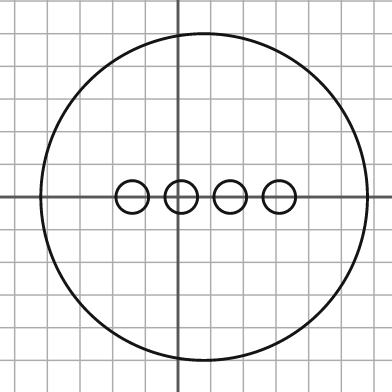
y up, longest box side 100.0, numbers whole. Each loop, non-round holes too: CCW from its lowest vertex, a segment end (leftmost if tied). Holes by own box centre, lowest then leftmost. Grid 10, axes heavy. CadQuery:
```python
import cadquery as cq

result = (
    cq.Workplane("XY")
    .moveTo(8.0, 0.0)
    .circle(50.0)
    .moveTo(-14.0, 0.0)
    .circle(5.0)
    .moveTo(1.0, 0.0)
    .circle(5.0)
    .moveTo(16.0, 0.0)
    .circle(5.0)
    .moveTo(31.0, 0.0)
    .circle(5.0)
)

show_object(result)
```